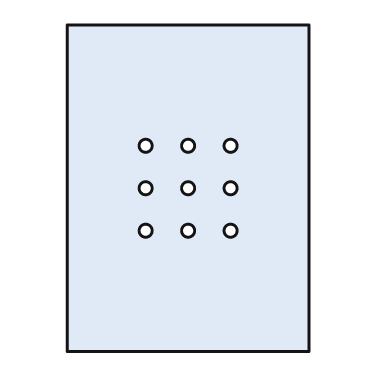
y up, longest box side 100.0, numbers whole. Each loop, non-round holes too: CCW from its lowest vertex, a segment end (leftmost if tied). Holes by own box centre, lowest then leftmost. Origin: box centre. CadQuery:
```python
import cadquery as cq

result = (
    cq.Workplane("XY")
    .moveTo(-37.0, -50.0)
    .lineTo(37.0, -50.0)
    .lineTo(37.0, 50.0)
    .lineTo(-37.0, 50.0)
    .close()
    .moveTo(-13.0, -13.0)
    .circle(2.0)
    .moveTo(0.0, -13.0)
    .circle(2.0)
    .moveTo(13.0, -13.0)
    .circle(2.0)
    .moveTo(-13.0, 0.0)
    .circle(2.0)
    .moveTo(0.0, 0.0)
    .circle(2.0)
    .moveTo(13.0, 0.0)
    .circle(2.0)
    .moveTo(-13.0, 13.0)
    .circle(2.0)
    .moveTo(0.0, 13.0)
    .circle(2.0)
    .moveTo(13.0, 13.0)
    .circle(2.0)
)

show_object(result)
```